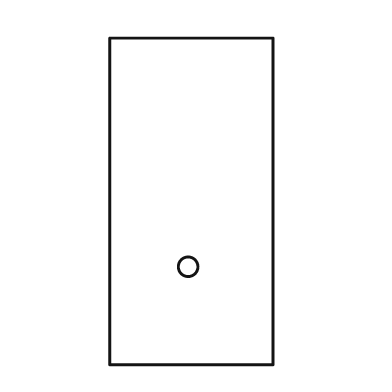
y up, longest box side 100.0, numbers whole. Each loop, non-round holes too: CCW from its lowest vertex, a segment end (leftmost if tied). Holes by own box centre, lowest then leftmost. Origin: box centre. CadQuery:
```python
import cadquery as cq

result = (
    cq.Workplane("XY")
    .moveTo(-25.0, -50.0)
    .lineTo(25.0, -50.0)
    .lineTo(25.0, 50.0)
    .lineTo(-25.0, 50.0)
    .close()
    .moveTo(-1.0, -20.0)
    .circle(3.0)
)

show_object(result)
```